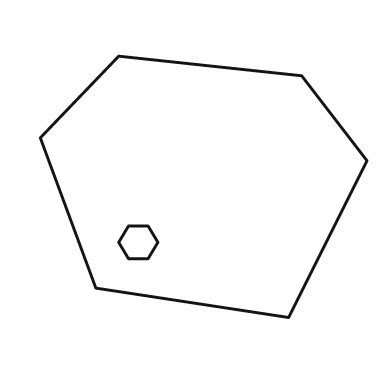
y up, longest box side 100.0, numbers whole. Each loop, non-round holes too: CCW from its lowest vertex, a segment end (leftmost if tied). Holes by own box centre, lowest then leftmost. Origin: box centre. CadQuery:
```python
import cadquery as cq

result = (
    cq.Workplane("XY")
    .moveTo(26.0, -40.0)
    .lineTo(50.0, 8.0)
    .lineTo(30.0, 34.0)
    .lineTo(-26.0, 40.0)
    .lineTo(-50.0, 15.0)
    .lineTo(-33.0, -31.0)
    .close()
    .moveTo(-23.0, -22.0)
    .lineTo(-17.0, -22.0)
    .lineTo(-14.0, -17.0)
    .lineTo(-17.0, -12.0)
    .lineTo(-23.0, -12.0)
    .lineTo(-26.0, -17.0)
    .close()
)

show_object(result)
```